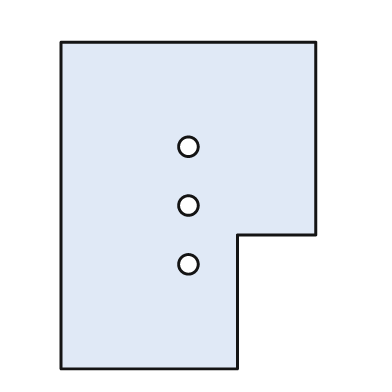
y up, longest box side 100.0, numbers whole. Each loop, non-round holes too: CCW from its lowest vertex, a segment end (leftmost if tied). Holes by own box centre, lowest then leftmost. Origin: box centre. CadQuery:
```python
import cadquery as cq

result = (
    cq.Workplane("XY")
    .moveTo(-39.0, -50.0)
    .lineTo(15.0, -50.0)
    .lineTo(15.0, -9.0)
    .lineTo(39.0, -9.0)
    .lineTo(39.0, 50.0)
    .lineTo(-39.0, 50.0)
    .close()
    .moveTo(0.0, -18.0)
    .circle(3.0)
    .moveTo(0.0, 0.0)
    .circle(3.0)
    .moveTo(0.0, 18.0)
    .circle(3.0)
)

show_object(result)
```